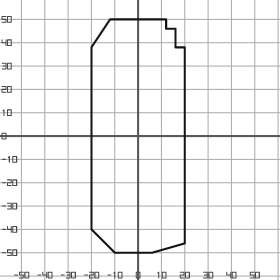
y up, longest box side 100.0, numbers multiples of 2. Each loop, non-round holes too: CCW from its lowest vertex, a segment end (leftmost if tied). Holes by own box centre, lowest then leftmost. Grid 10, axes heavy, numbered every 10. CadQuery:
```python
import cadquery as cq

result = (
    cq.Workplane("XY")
    .moveTo(-10.0, -50.0)
    .lineTo(6.0, -50.0)
    .lineTo(20.0, -46.0)
    .lineTo(20.0, 38.0)
    .lineTo(16.0, 38.0)
    .lineTo(16.0, 46.0)
    .lineTo(12.0, 46.0)
    .lineTo(12.0, 50.0)
    .lineTo(-12.0, 50.0)
    .lineTo(-20.0, 38.0)
    .lineTo(-20.0, -40.0)
    .close()
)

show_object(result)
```